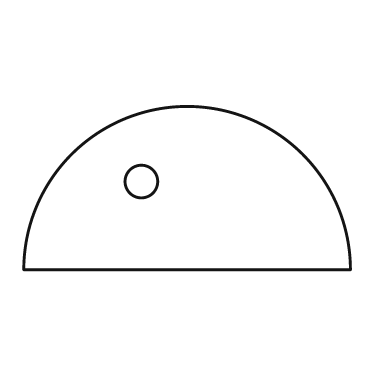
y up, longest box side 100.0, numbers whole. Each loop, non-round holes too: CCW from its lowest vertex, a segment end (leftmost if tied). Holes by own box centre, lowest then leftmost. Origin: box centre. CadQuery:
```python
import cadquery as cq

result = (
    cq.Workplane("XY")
    .moveTo(-50.0, -25.0)
    .lineTo(50.0, -25.0)
    .threePointArc((0.0, 25.0), (-50.0, -25.0))
    .close()
    .moveTo(-14.0, 2.0)
    .circle(5.0)
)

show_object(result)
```